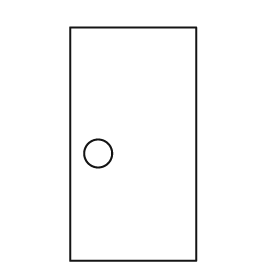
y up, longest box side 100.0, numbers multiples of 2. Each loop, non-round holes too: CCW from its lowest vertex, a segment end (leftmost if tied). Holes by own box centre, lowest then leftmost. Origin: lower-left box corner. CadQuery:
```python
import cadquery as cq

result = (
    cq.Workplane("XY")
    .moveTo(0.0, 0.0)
    .lineTo(54.0, 0.0)
    .lineTo(54.0, 100.0)
    .lineTo(0.0, 100.0)
    .close()
    .moveTo(12.0, 46.0)
    .circle(6.0)
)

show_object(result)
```